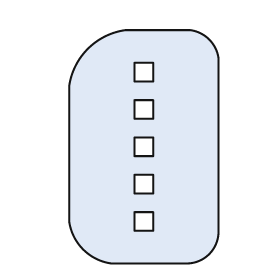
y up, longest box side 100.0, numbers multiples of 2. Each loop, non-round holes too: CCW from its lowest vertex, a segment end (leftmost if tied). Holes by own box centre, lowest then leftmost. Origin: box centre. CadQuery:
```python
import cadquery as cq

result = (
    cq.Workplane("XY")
    .moveTo(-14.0, -50.0)
    .lineTo(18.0, -50.0)
    .threePointArc((28.0, -46.0), (32.0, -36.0))
    .lineTo(32.0, 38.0)
    .threePointArc((28.0, 46.0), (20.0, 50.0))
    .lineTo(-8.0, 50.0)
    .threePointArc((-24.0, 42.0), (-32.0, 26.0))
    .lineTo(-32.0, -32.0)
    .threePointArc((-26.0, -44.0), (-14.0, -50.0))
    .close()
    .moveTo(-4.0, -36.0)
    .lineTo(4.0, -36.0)
    .lineTo(4.0, -28.0)
    .lineTo(-4.0, -28.0)
    .close()
    .moveTo(-4.0, -20.0)
    .lineTo(4.0, -20.0)
    .lineTo(4.0, -12.0)
    .lineTo(-4.0, -12.0)
    .close()
    .moveTo(-4.0, -4.0)
    .lineTo(4.0, -4.0)
    .lineTo(4.0, 4.0)
    .lineTo(-4.0, 4.0)
    .close()
    .moveTo(-4.0, 12.0)
    .lineTo(4.0, 12.0)
    .lineTo(4.0, 20.0)
    .lineTo(-4.0, 20.0)
    .close()
    .moveTo(-4.0, 28.0)
    .lineTo(4.0, 28.0)
    .lineTo(4.0, 36.0)
    .lineTo(-4.0, 36.0)
    .close()
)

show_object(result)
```